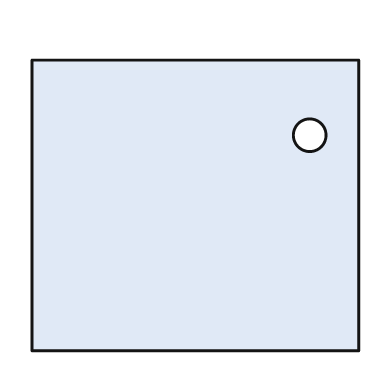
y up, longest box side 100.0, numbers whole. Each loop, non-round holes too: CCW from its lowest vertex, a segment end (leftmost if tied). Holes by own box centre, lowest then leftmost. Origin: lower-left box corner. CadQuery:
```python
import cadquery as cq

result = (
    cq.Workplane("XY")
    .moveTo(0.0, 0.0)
    .lineTo(100.0, 0.0)
    .lineTo(100.0, 89.0)
    .lineTo(0.0, 89.0)
    .close()
    .moveTo(85.0, 66.0)
    .circle(5.0)
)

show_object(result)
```